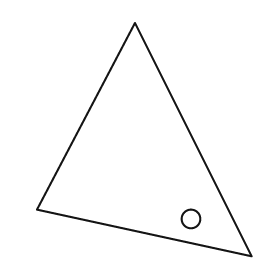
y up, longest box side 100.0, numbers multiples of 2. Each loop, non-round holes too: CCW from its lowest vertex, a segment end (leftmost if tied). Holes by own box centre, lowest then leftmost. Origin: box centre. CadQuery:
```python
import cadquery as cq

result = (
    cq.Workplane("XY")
    .moveTo(46.0, -50.0)
    .lineTo(-4.0, 50.0)
    .lineTo(-46.0, -30.0)
    .close()
    .moveTo(20.0, -34.0)
    .circle(4.0)
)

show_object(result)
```